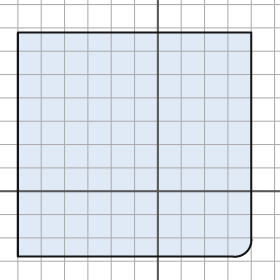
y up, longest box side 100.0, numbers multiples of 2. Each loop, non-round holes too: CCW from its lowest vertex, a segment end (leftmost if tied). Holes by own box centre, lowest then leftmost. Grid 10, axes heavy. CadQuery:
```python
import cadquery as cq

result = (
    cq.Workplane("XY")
    .moveTo(-60.0, -28.0)
    .lineTo(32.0, -28.0)
    .threePointArc((38.0, -26.0), (40.0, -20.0))
    .lineTo(40.0, 68.0)
    .lineTo(-60.0, 68.0)
    .close()
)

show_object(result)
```